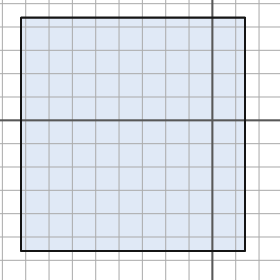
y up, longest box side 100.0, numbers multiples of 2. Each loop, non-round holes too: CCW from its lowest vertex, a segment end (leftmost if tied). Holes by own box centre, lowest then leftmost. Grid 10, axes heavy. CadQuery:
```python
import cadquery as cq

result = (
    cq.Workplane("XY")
    .moveTo(-82.0, -56.0)
    .lineTo(14.0, -56.0)
    .lineTo(14.0, 44.0)
    .lineTo(-82.0, 44.0)
    .close()
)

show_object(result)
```